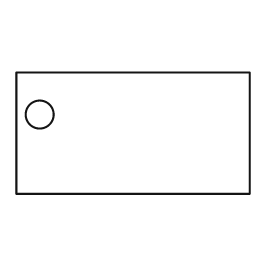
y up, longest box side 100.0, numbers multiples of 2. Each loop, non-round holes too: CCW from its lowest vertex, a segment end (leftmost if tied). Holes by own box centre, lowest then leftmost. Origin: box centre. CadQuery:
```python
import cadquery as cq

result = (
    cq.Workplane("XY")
    .moveTo(-50.0, -26.0)
    .lineTo(50.0, -26.0)
    .lineTo(50.0, 26.0)
    .lineTo(-50.0, 26.0)
    .close()
    .moveTo(-40.0, 8.0)
    .circle(6.0)
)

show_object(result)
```